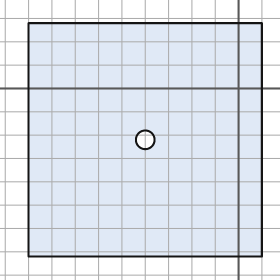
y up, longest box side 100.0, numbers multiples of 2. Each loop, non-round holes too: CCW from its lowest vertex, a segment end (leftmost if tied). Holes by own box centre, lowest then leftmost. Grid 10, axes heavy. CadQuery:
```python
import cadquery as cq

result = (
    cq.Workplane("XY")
    .moveTo(-90.0, -72.0)
    .lineTo(10.0, -72.0)
    .lineTo(10.0, 28.0)
    .lineTo(-90.0, 28.0)
    .close()
    .moveTo(-40.0, -22.0)
    .circle(4.0)
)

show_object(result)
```